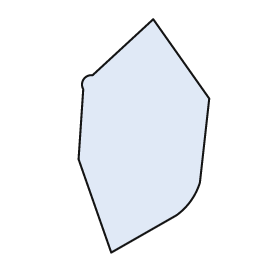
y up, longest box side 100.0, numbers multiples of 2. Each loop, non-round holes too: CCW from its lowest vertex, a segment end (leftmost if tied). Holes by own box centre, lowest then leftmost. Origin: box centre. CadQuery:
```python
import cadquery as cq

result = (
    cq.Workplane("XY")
    .moveTo(-14.0, -50.0)
    .lineTo(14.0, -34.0)
    .threePointArc((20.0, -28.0), (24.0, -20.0))
    .lineTo(28.0, 16.0)
    .lineTo(4.0, 50.0)
    .lineTo(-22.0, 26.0)
    .threePointArc((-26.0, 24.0), (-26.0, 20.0))
    .lineTo(-28.0, -10.0)
    .close()
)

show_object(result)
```